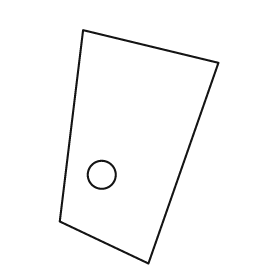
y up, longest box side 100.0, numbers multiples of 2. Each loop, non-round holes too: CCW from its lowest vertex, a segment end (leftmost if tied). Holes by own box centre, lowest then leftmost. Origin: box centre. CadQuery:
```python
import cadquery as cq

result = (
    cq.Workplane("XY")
    .moveTo(4.0, -50.0)
    .lineTo(34.0, 36.0)
    .lineTo(-24.0, 50.0)
    .lineTo(-34.0, -32.0)
    .close()
    .moveTo(-16.0, -12.0)
    .circle(6.0)
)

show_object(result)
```